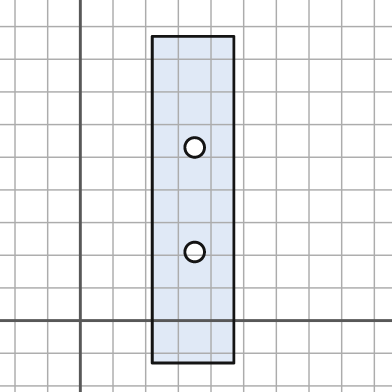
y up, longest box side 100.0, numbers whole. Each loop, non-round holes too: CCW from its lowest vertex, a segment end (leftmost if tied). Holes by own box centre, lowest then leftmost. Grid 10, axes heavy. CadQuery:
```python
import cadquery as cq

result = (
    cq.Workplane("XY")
    .moveTo(22.0, -13.0)
    .lineTo(47.0, -13.0)
    .lineTo(47.0, 87.0)
    .lineTo(22.0, 87.0)
    .close()
    .moveTo(35.0, 21.0)
    .circle(3.0)
    .moveTo(35.0, 53.0)
    .circle(3.0)
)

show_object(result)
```